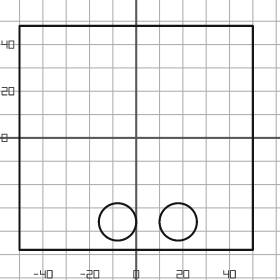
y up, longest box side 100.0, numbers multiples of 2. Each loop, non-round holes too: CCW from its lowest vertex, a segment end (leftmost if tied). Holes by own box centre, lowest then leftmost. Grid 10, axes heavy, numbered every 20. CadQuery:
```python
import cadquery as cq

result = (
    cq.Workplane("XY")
    .moveTo(-50.0, -48.0)
    .lineTo(50.0, -48.0)
    .lineTo(50.0, 48.0)
    .lineTo(-50.0, 48.0)
    .close()
    .moveTo(-8.0, -36.0)
    .circle(8.0)
    .moveTo(18.0, -36.0)
    .circle(8.0)
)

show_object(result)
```